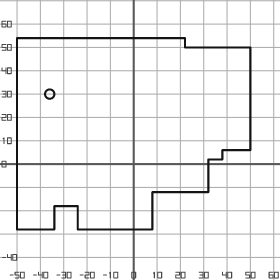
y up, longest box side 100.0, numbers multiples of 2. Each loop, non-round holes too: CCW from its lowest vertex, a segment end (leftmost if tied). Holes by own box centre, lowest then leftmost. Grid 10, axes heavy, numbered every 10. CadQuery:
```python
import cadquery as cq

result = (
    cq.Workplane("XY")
    .moveTo(-50.0, -28.0)
    .lineTo(-34.0, -28.0)
    .lineTo(-34.0, -18.0)
    .lineTo(-24.0, -18.0)
    .lineTo(-24.0, -28.0)
    .lineTo(8.0, -28.0)
    .lineTo(8.0, -12.0)
    .lineTo(32.0, -12.0)
    .lineTo(32.0, 2.0)
    .lineTo(38.0, 2.0)
    .lineTo(38.0, 6.0)
    .lineTo(50.0, 6.0)
    .lineTo(50.0, 50.0)
    .lineTo(22.0, 50.0)
    .lineTo(22.0, 54.0)
    .lineTo(-50.0, 54.0)
    .close()
    .moveTo(-36.0, 30.0)
    .circle(2.0)
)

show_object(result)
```